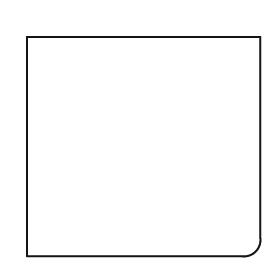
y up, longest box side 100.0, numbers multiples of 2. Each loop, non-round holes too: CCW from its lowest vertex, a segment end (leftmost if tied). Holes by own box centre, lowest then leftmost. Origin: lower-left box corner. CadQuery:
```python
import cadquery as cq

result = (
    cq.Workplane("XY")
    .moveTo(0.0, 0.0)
    .lineTo(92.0, 0.0)
    .threePointArc((98.0, 2.0), (100.0, 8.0))
    .lineTo(100.0, 94.0)
    .lineTo(0.0, 94.0)
    .close()
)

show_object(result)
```